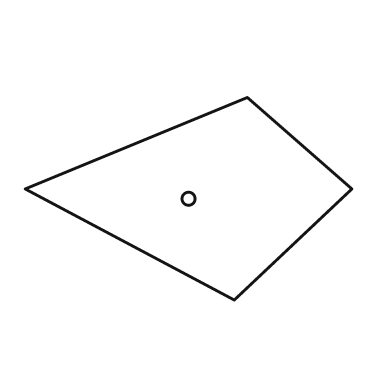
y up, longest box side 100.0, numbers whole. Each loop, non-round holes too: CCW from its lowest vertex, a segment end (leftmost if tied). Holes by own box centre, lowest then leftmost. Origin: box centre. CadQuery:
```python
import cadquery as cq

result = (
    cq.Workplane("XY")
    .moveTo(14.0, -31.0)
    .lineTo(50.0, 3.0)
    .lineTo(18.0, 31.0)
    .lineTo(-50.0, 3.0)
    .close()
    .moveTo(0.0, 0.0)
    .circle(2.0)
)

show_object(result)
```